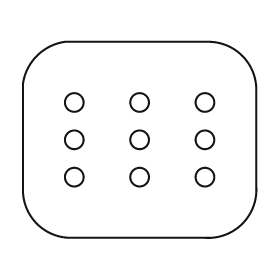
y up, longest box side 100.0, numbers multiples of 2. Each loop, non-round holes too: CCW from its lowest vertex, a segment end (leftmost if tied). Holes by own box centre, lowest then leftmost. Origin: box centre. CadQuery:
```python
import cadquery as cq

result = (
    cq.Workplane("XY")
    .moveTo(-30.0, -42.0)
    .lineTo(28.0, -42.0)
    .threePointArc((44.0, -36.0), (50.0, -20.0))
    .lineTo(50.0, 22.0)
    .threePointArc((44.0, 36.0), (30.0, 42.0))
    .lineTo(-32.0, 42.0)
    .threePointArc((-44.0, 36.0), (-50.0, 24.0))
    .lineTo(-50.0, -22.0)
    .threePointArc((-44.0, -36.0), (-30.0, -42.0))
    .close()
    .moveTo(-28.0, -16.0)
    .circle(4.0)
    .moveTo(0.0, -16.0)
    .circle(4.0)
    .moveTo(28.0, -16.0)
    .circle(4.0)
    .moveTo(-28.0, 0.0)
    .circle(4.0)
    .moveTo(0.0, 0.0)
    .circle(4.0)
    .moveTo(28.0, 0.0)
    .circle(4.0)
    .moveTo(-28.0, 16.0)
    .circle(4.0)
    .moveTo(0.0, 16.0)
    .circle(4.0)
    .moveTo(28.0, 16.0)
    .circle(4.0)
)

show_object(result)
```